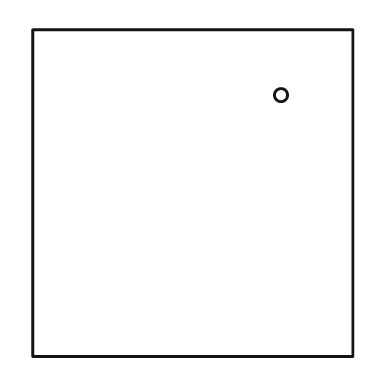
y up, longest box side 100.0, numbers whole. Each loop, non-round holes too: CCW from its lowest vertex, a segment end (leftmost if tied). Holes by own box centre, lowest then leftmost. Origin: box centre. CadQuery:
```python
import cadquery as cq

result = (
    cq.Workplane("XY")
    .moveTo(-49.0, -50.0)
    .lineTo(49.0, -50.0)
    .lineTo(49.0, 50.0)
    .lineTo(-49.0, 50.0)
    .close()
    .moveTo(27.0, 30.0)
    .circle(2.0)
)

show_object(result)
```